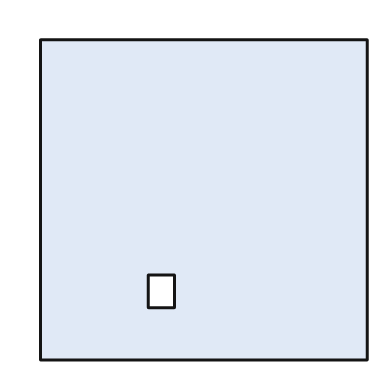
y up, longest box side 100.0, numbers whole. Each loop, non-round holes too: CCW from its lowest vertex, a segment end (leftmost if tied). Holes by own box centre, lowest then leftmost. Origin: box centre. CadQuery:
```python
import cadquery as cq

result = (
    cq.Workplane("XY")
    .moveTo(-50.0, -49.0)
    .lineTo(50.0, -49.0)
    .lineTo(50.0, 49.0)
    .lineTo(-50.0, 49.0)
    .close()
    .moveTo(-17.0, -33.0)
    .lineTo(-9.0, -33.0)
    .lineTo(-9.0, -23.0)
    .lineTo(-17.0, -23.0)
    .close()
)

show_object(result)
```